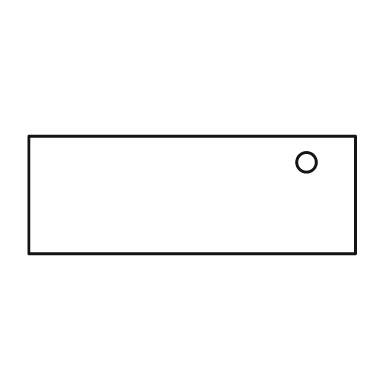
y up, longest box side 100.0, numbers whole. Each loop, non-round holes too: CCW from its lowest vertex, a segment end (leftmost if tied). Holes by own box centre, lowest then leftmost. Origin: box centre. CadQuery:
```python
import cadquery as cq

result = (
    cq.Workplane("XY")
    .moveTo(-50.0, -18.0)
    .lineTo(50.0, -18.0)
    .lineTo(50.0, 18.0)
    .lineTo(-50.0, 18.0)
    .close()
    .moveTo(35.0, 10.0)
    .circle(3.0)
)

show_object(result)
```